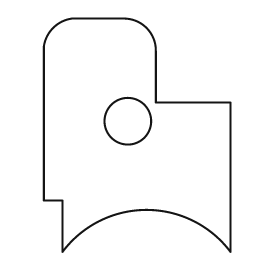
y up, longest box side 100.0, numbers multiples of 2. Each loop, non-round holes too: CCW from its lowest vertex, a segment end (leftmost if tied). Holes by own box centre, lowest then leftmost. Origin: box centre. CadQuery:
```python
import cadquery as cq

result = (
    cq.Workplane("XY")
    .moveTo(-32.0, -50.0)
    .threePointArc((4.0, -32.0), (40.0, -50.0))
    .lineTo(40.0, 14.0)
    .lineTo(8.0, 14.0)
    .lineTo(8.0, 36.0)
    .threePointArc((4.0, 46.0), (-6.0, 50.0))
    .lineTo(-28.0, 50.0)
    .threePointArc((-36.0, 46.0), (-40.0, 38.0))
    .lineTo(-40.0, -28.0)
    .lineTo(-32.0, -28.0)
    .close()
    .moveTo(-4.0, 6.0)
    .circle(10.0)
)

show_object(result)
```